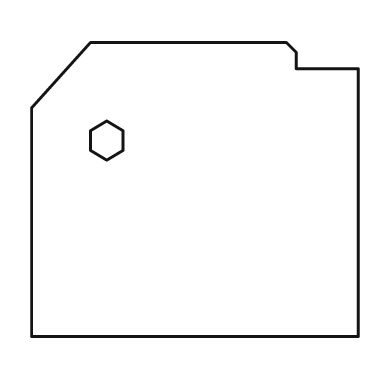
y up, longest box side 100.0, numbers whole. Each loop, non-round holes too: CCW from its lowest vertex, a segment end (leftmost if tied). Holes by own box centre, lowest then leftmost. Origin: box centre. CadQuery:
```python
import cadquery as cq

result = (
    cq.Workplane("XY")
    .moveTo(-50.0, -45.0)
    .lineTo(50.0, -45.0)
    .lineTo(50.0, 37.0)
    .lineTo(31.0, 37.0)
    .lineTo(31.0, 42.0)
    .lineTo(28.0, 45.0)
    .lineTo(-32.0, 45.0)
    .lineTo(-50.0, 25.0)
    .close()
    .moveTo(-27.0, 9.0)
    .lineTo(-22.0, 12.0)
    .lineTo(-22.0, 18.0)
    .lineTo(-27.0, 21.0)
    .lineTo(-32.0, 18.0)
    .lineTo(-32.0, 12.0)
    .close()
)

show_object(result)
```